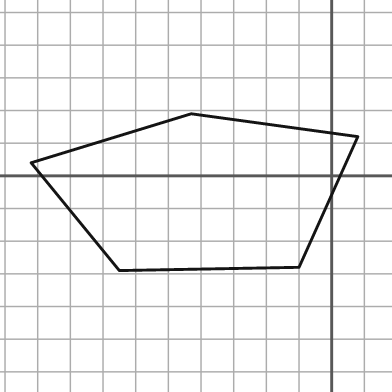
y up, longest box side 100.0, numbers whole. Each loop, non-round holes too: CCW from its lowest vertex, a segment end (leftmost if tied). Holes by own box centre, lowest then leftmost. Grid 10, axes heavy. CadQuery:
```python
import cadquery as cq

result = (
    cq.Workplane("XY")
    .moveTo(-65.0, -29.0)
    .lineTo(-10.0, -28.0)
    .lineTo(8.0, 12.0)
    .lineTo(-43.0, 19.0)
    .lineTo(-92.0, 4.0)
    .close()
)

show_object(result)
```